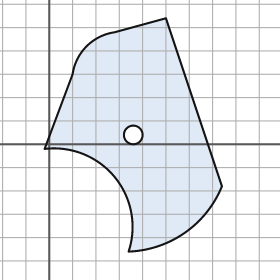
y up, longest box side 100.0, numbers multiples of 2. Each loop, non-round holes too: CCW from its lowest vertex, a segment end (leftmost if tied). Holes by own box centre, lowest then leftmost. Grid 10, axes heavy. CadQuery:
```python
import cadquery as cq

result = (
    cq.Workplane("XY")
    .moveTo(34.0, -46.0)
    .threePointArc((58.0, -38.0), (74.0, -18.0))
    .lineTo(50.0, 54.0)
    .lineTo(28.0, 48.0)
    .threePointArc((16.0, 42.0), (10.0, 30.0))
    .lineTo(-2.0, -2.0)
    .threePointArc((28.0, -14.0), (34.0, -46.0))
    .close()
    .moveTo(36.0, 4.0)
    .circle(4.0)
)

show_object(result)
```